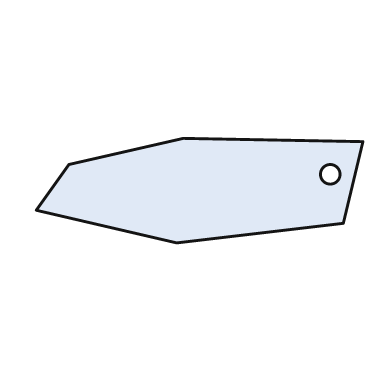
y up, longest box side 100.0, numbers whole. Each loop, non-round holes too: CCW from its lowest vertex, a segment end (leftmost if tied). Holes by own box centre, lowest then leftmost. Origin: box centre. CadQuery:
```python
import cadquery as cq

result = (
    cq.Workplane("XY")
    .moveTo(-7.0, -16.0)
    .lineTo(44.0, -10.0)
    .lineTo(50.0, 15.0)
    .lineTo(-5.0, 16.0)
    .lineTo(-40.0, 8.0)
    .lineTo(-50.0, -6.0)
    .close()
    .moveTo(40.0, 5.0)
    .circle(3.0)
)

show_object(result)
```